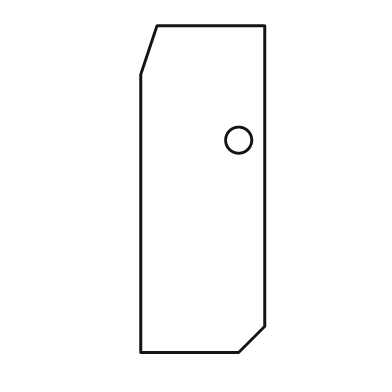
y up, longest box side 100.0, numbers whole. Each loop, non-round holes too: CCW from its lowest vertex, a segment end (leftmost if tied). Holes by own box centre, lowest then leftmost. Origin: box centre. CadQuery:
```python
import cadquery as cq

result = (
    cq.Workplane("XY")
    .moveTo(-19.0, -50.0)
    .lineTo(11.0, -50.0)
    .lineTo(19.0, -42.0)
    .lineTo(19.0, 50.0)
    .lineTo(-14.0, 50.0)
    .lineTo(-19.0, 35.0)
    .close()
    .moveTo(11.0, 15.0)
    .circle(4.0)
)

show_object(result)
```